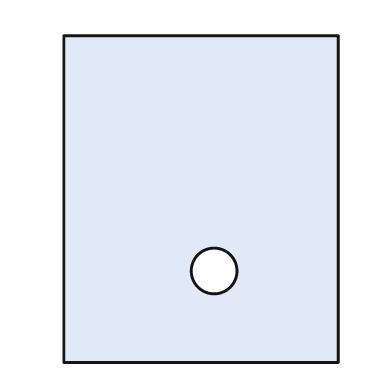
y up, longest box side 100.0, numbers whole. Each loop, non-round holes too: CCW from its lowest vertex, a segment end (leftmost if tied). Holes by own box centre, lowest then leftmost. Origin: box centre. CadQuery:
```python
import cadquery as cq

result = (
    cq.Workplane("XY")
    .moveTo(-42.0, -50.0)
    .lineTo(42.0, -50.0)
    .lineTo(42.0, 50.0)
    .lineTo(-42.0, 50.0)
    .close()
    .moveTo(4.0, -22.0)
    .circle(7.0)
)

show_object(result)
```